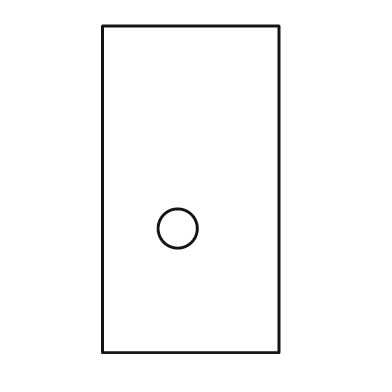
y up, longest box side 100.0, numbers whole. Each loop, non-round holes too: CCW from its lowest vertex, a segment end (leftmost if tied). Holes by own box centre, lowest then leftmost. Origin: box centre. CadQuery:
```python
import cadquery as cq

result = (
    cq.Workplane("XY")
    .moveTo(-27.0, -50.0)
    .lineTo(27.0, -50.0)
    .lineTo(27.0, 50.0)
    .lineTo(-27.0, 50.0)
    .close()
    .moveTo(-4.0, -12.0)
    .circle(6.0)
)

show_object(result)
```